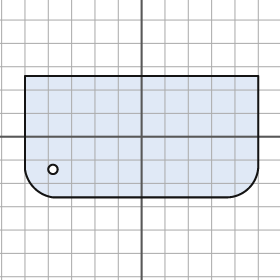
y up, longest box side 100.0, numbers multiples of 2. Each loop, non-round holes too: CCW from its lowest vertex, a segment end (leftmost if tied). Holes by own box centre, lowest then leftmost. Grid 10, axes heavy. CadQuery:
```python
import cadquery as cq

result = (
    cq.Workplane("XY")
    .moveTo(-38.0, -26.0)
    .lineTo(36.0, -26.0)
    .threePointArc((46.0, -22.0), (50.0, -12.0))
    .lineTo(50.0, 26.0)
    .lineTo(-50.0, 26.0)
    .lineTo(-50.0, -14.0)
    .threePointArc((-46.0, -22.0), (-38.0, -26.0))
    .close()
    .moveTo(-38.0, -14.0)
    .circle(2.0)
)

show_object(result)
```